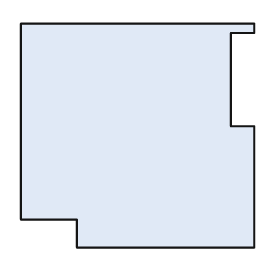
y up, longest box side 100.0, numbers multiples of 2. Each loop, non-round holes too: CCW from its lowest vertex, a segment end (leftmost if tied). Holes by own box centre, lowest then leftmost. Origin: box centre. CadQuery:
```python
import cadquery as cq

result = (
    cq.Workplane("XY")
    .moveTo(-26.0, -48.0)
    .lineTo(50.0, -48.0)
    .lineTo(50.0, 4.0)
    .lineTo(40.0, 4.0)
    .lineTo(40.0, 44.0)
    .lineTo(50.0, 44.0)
    .lineTo(50.0, 48.0)
    .lineTo(-50.0, 48.0)
    .lineTo(-50.0, -36.0)
    .lineTo(-26.0, -36.0)
    .close()
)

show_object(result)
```